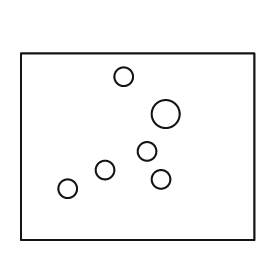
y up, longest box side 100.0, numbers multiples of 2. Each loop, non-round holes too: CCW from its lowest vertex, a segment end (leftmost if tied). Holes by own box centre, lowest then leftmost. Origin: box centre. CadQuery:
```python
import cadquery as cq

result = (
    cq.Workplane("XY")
    .moveTo(-50.0, -40.0)
    .lineTo(50.0, -40.0)
    .lineTo(50.0, 40.0)
    .lineTo(-50.0, 40.0)
    .close()
    .moveTo(-30.0, -18.0)
    .circle(4.0)
    .moveTo(10.0, -14.0)
    .circle(4.0)
    .moveTo(-14.0, -10.0)
    .circle(4.0)
    .moveTo(4.0, -2.0)
    .circle(4.0)
    .moveTo(12.0, 14.0)
    .circle(6.0)
    .moveTo(-6.0, 30.0)
    .circle(4.0)
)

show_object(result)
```